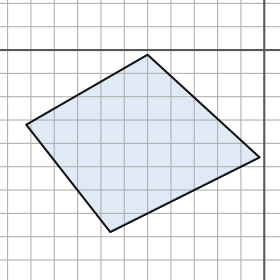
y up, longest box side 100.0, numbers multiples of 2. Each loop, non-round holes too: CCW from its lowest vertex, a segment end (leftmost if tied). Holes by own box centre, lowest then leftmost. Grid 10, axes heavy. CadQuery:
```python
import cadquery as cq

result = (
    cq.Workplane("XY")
    .moveTo(-66.0, -78.0)
    .lineTo(-2.0, -46.0)
    .lineTo(-50.0, -2.0)
    .lineTo(-102.0, -32.0)
    .close()
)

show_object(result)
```